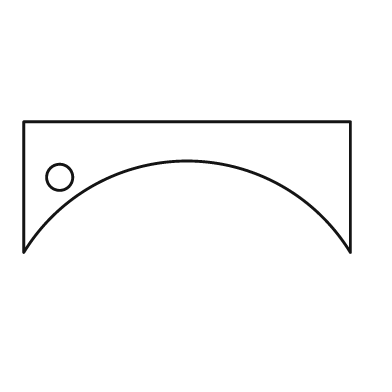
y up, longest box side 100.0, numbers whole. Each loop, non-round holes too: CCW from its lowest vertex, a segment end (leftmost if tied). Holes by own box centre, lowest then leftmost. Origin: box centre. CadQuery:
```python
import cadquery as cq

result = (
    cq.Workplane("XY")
    .moveTo(-50.0, -20.0)
    .threePointArc((0.0, 8.0), (50.0, -20.0))
    .lineTo(50.0, 20.0)
    .lineTo(-50.0, 20.0)
    .close()
    .moveTo(-39.0, 3.0)
    .circle(4.0)
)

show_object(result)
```